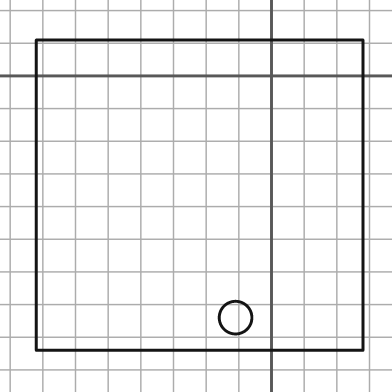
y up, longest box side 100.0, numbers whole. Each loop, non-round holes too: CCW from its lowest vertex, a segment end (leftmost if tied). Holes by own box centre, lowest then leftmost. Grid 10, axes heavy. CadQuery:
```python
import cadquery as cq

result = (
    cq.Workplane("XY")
    .moveTo(-72.0, -84.0)
    .lineTo(28.0, -84.0)
    .lineTo(28.0, 11.0)
    .lineTo(-72.0, 11.0)
    .close()
    .moveTo(-11.0, -74.0)
    .circle(5.0)
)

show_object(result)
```